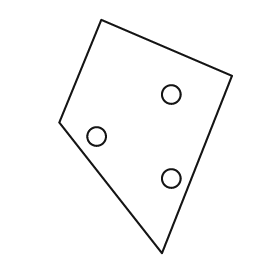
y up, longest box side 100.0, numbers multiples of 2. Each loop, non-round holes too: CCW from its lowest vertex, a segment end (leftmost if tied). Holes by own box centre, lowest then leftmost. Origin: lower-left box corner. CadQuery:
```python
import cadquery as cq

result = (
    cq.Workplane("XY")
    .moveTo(44.0, 0.0)
    .lineTo(74.0, 76.0)
    .lineTo(18.0, 100.0)
    .lineTo(0.0, 56.0)
    .close()
    .moveTo(48.0, 32.0)
    .circle(4.0)
    .moveTo(16.0, 50.0)
    .circle(4.0)
    .moveTo(48.0, 68.0)
    .circle(4.0)
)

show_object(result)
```